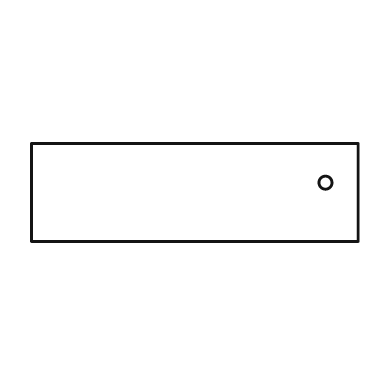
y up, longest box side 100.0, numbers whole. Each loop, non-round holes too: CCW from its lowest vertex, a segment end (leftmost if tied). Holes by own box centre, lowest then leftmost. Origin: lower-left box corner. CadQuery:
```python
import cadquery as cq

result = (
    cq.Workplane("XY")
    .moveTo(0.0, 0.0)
    .lineTo(100.0, 0.0)
    .lineTo(100.0, 30.0)
    .lineTo(0.0, 30.0)
    .close()
    .moveTo(90.0, 18.0)
    .circle(2.0)
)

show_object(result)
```